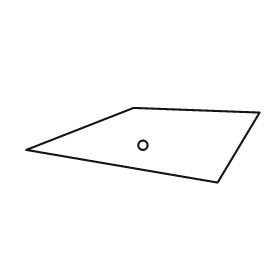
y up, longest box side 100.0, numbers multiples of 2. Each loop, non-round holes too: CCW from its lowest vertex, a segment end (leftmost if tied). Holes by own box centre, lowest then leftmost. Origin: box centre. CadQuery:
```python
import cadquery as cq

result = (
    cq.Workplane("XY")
    .moveTo(32.0, -16.0)
    .lineTo(50.0, 14.0)
    .lineTo(-4.0, 16.0)
    .lineTo(-50.0, -2.0)
    .close()
    .moveTo(0.0, 0.0)
    .circle(2.0)
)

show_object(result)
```